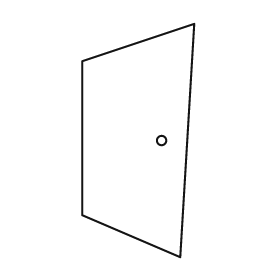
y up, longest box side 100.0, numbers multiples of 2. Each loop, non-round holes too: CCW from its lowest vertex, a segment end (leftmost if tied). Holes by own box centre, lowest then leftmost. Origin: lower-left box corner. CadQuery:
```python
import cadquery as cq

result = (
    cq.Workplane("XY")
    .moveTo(42.0, 0.0)
    .lineTo(48.0, 100.0)
    .lineTo(0.0, 84.0)
    .lineTo(0.0, 18.0)
    .close()
    .moveTo(34.0, 50.0)
    .circle(2.0)
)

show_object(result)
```